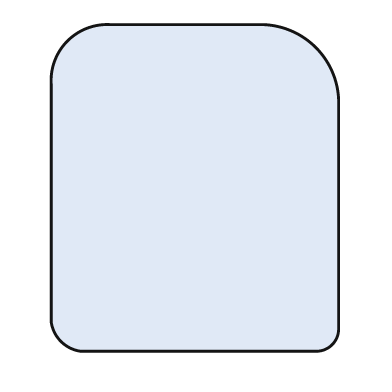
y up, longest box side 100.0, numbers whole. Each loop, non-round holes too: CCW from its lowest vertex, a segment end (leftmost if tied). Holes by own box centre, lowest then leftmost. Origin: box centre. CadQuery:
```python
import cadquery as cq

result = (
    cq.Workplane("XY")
    .moveTo(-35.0, -50.0)
    .lineTo(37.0, -50.0)
    .threePointArc((42.0, -48.0), (44.0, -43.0))
    .lineTo(44.0, 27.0)
    .threePointArc((37.0, 43.0), (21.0, 50.0))
    .lineTo(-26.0, 50.0)
    .threePointArc((-39.0, 45.0), (-44.0, 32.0))
    .lineTo(-44.0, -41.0)
    .threePointArc((-41.0, -47.0), (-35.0, -50.0))
    .close()
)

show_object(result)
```